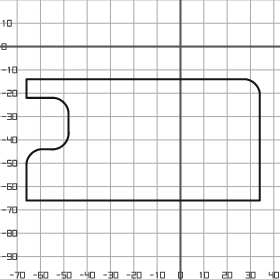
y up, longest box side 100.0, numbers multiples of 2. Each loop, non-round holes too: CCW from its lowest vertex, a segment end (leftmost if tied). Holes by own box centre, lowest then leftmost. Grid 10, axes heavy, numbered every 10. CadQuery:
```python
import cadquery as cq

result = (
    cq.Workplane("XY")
    .moveTo(-66.0, -66.0)
    .lineTo(34.0, -66.0)
    .lineTo(34.0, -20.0)
    .threePointArc((32.0, -16.0), (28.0, -14.0))
    .lineTo(-66.0, -14.0)
    .lineTo(-66.0, -22.0)
    .lineTo(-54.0, -22.0)
    .threePointArc((-50.0, -24.0), (-48.0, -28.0))
    .lineTo(-48.0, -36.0)
    .threePointArc((-50.0, -42.0), (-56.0, -44.0))
    .lineTo(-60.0, -44.0)
    .threePointArc((-64.0, -46.0), (-66.0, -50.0))
    .close()
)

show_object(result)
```